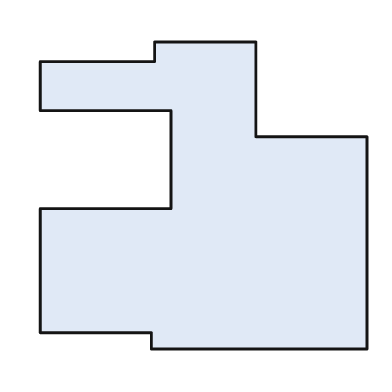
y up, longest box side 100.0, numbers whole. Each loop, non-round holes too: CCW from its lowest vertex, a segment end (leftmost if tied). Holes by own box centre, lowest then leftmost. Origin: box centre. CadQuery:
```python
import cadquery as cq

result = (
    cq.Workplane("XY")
    .moveTo(-16.0, -47.0)
    .lineTo(50.0, -47.0)
    .lineTo(50.0, 18.0)
    .lineTo(16.0, 18.0)
    .lineTo(16.0, 47.0)
    .lineTo(-15.0, 47.0)
    .lineTo(-15.0, 41.0)
    .lineTo(-50.0, 41.0)
    .lineTo(-50.0, 26.0)
    .lineTo(-10.0, 26.0)
    .lineTo(-10.0, -4.0)
    .lineTo(-50.0, -4.0)
    .lineTo(-50.0, -42.0)
    .lineTo(-16.0, -42.0)
    .close()
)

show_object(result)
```